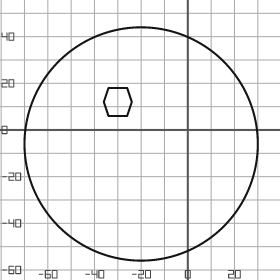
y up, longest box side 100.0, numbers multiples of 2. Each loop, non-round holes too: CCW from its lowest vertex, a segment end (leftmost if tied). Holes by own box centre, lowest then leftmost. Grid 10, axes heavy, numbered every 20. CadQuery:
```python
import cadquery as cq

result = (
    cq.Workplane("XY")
    .moveTo(-20.0, -6.0)
    .circle(50.0)
    .moveTo(-34.0, 6.0)
    .lineTo(-26.0, 6.0)
    .lineTo(-24.0, 12.0)
    .lineTo(-26.0, 18.0)
    .lineTo(-34.0, 18.0)
    .lineTo(-36.0, 12.0)
    .close()
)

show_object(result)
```